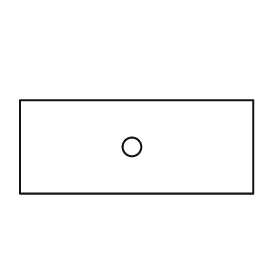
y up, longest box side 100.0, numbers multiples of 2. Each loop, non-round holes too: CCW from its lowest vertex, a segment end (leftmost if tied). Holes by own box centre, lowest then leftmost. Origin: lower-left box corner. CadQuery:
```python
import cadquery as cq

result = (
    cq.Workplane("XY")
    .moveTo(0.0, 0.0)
    .lineTo(100.0, 0.0)
    .lineTo(100.0, 40.0)
    .lineTo(0.0, 40.0)
    .close()
    .moveTo(48.0, 20.0)
    .circle(4.0)
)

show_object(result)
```